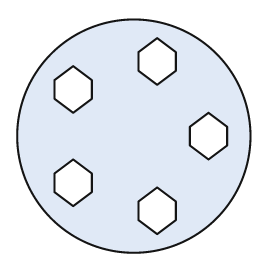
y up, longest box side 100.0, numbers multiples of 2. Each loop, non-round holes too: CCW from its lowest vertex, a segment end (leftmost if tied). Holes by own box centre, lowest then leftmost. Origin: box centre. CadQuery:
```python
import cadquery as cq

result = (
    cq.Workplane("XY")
    .moveTo(0.0, 0.0)
    .circle(50.0)
    .moveTo(10.0, -42.0)
    .lineTo(18.0, -36.0)
    .lineTo(18.0, -28.0)
    .lineTo(10.0, -22.0)
    .lineTo(2.0, -28.0)
    .lineTo(2.0, -36.0)
    .close()
    .moveTo(-26.0, -30.0)
    .lineTo(-18.0, -24.0)
    .lineTo(-18.0, -16.0)
    .lineTo(-26.0, -10.0)
    .lineTo(-34.0, -16.0)
    .lineTo(-34.0, -24.0)
    .close()
    .moveTo(32.0, -10.0)
    .lineTo(40.0, -4.0)
    .lineTo(40.0, 4.0)
    .lineTo(32.0, 10.0)
    .lineTo(24.0, 4.0)
    .lineTo(24.0, -4.0)
    .close()
    .moveTo(-26.0, 10.0)
    .lineTo(-18.0, 16.0)
    .lineTo(-18.0, 24.0)
    .lineTo(-26.0, 30.0)
    .lineTo(-34.0, 24.0)
    .lineTo(-34.0, 16.0)
    .close()
    .moveTo(10.0, 22.0)
    .lineTo(18.0, 28.0)
    .lineTo(18.0, 36.0)
    .lineTo(10.0, 42.0)
    .lineTo(2.0, 36.0)
    .lineTo(2.0, 28.0)
    .close()
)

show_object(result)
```